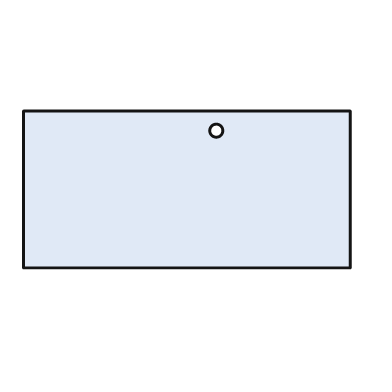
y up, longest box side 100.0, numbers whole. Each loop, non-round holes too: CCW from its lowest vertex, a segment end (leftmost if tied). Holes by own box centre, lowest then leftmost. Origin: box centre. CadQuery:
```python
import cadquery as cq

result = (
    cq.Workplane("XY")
    .moveTo(-50.0, -24.0)
    .lineTo(50.0, -24.0)
    .lineTo(50.0, 24.0)
    .lineTo(-50.0, 24.0)
    .close()
    .moveTo(9.0, 18.0)
    .circle(2.0)
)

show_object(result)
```